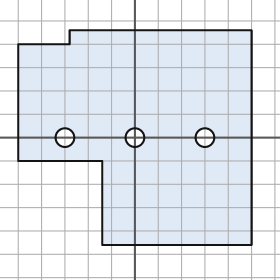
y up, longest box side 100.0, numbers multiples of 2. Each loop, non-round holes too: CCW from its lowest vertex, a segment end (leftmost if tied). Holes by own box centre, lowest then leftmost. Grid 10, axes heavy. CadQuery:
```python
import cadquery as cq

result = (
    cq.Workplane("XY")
    .moveTo(-14.0, -46.0)
    .lineTo(50.0, -46.0)
    .lineTo(50.0, 46.0)
    .lineTo(-28.0, 46.0)
    .lineTo(-28.0, 40.0)
    .lineTo(-50.0, 40.0)
    .lineTo(-50.0, -10.0)
    .lineTo(-14.0, -10.0)
    .close()
    .moveTo(-30.0, 0.0)
    .circle(4.0)
    .moveTo(0.0, 0.0)
    .circle(4.0)
    .moveTo(30.0, 0.0)
    .circle(4.0)
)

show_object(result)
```